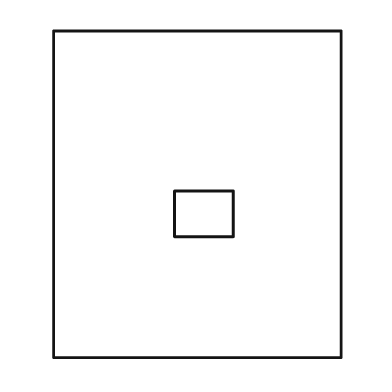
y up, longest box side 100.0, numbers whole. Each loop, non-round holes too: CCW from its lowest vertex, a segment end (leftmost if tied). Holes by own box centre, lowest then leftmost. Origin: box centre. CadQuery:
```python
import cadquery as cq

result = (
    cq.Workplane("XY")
    .moveTo(-44.0, -50.0)
    .lineTo(44.0, -50.0)
    .lineTo(44.0, 50.0)
    .lineTo(-44.0, 50.0)
    .close()
    .moveTo(-7.0, -13.0)
    .lineTo(11.0, -13.0)
    .lineTo(11.0, 1.0)
    .lineTo(-7.0, 1.0)
    .close()
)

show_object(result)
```